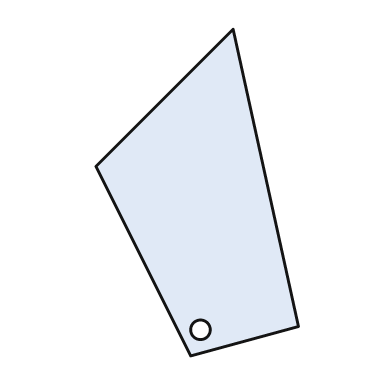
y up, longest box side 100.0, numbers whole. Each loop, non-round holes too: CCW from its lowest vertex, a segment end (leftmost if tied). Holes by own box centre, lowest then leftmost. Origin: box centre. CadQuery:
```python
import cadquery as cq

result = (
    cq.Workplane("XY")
    .moveTo(-2.0, -50.0)
    .lineTo(31.0, -41.0)
    .lineTo(11.0, 50.0)
    .lineTo(-31.0, 8.0)
    .close()
    .moveTo(1.0, -42.0)
    .circle(3.0)
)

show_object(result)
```